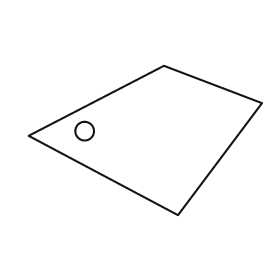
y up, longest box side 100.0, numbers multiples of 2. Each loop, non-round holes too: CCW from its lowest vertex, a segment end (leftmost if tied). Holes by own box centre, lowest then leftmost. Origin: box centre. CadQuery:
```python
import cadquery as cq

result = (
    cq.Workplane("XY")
    .moveTo(14.0, -32.0)
    .lineTo(50.0, 16.0)
    .lineTo(8.0, 32.0)
    .lineTo(-50.0, 2.0)
    .close()
    .moveTo(-26.0, 4.0)
    .circle(4.0)
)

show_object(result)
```